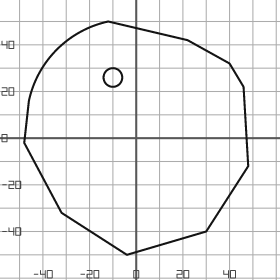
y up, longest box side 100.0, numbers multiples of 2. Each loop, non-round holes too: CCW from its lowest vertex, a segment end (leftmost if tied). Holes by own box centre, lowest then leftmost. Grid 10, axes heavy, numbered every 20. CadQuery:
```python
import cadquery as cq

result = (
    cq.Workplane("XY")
    .moveTo(-4.0, -50.0)
    .lineTo(30.0, -40.0)
    .lineTo(48.0, -12.0)
    .lineTo(46.0, 22.0)
    .lineTo(40.0, 32.0)
    .lineTo(22.0, 42.0)
    .lineTo(-12.0, 50.0)
    .threePointArc((-34.0, 38.0), (-46.0, 16.0))
    .lineTo(-48.0, -2.0)
    .lineTo(-32.0, -32.0)
    .close()
    .moveTo(-10.0, 26.0)
    .circle(4.0)
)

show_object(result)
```